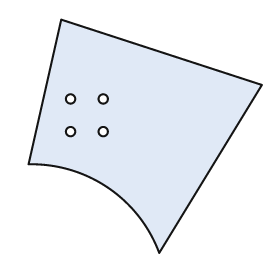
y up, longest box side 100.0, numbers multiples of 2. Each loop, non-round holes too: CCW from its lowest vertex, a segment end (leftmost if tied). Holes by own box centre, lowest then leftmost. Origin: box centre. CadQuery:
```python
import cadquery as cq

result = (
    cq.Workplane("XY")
    .moveTo(6.0, -50.0)
    .lineTo(50.0, 22.0)
    .lineTo(-36.0, 50.0)
    .lineTo(-50.0, -12.0)
    .threePointArc((-16.0, -22.0), (6.0, -50.0))
    .close()
    .moveTo(-32.0, 2.0)
    .circle(2.0)
    .moveTo(-18.0, 2.0)
    .circle(2.0)
    .moveTo(-32.0, 16.0)
    .circle(2.0)
    .moveTo(-18.0, 16.0)
    .circle(2.0)
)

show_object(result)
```